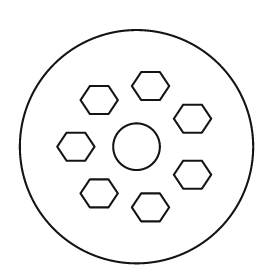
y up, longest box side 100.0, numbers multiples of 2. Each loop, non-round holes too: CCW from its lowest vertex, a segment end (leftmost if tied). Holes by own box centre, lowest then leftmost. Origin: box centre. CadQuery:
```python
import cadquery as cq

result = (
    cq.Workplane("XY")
    .moveTo(0.0, 0.0)
    .circle(50.0)
    .moveTo(2.0, -32.0)
    .lineTo(10.0, -32.0)
    .lineTo(14.0, -26.0)
    .lineTo(10.0, -20.0)
    .lineTo(2.0, -20.0)
    .lineTo(-2.0, -26.0)
    .close()
    .moveTo(-20.0, -26.0)
    .lineTo(-12.0, -26.0)
    .lineTo(-8.0, -20.0)
    .lineTo(-12.0, -14.0)
    .lineTo(-20.0, -14.0)
    .lineTo(-24.0, -20.0)
    .close()
    .moveTo(20.0, -18.0)
    .lineTo(28.0, -18.0)
    .lineTo(32.0, -12.0)
    .lineTo(28.0, -6.0)
    .lineTo(20.0, -6.0)
    .lineTo(16.0, -12.0)
    .close()
    .moveTo(-30.0, -6.0)
    .lineTo(-22.0, -6.0)
    .lineTo(-18.0, 0.0)
    .lineTo(-22.0, 6.0)
    .lineTo(-30.0, 6.0)
    .lineTo(-34.0, 0.0)
    .close()
    .moveTo(0.0, 0.0)
    .circle(10.0)
    .moveTo(20.0, 6.0)
    .lineTo(28.0, 6.0)
    .lineTo(32.0, 12.0)
    .lineTo(28.0, 18.0)
    .lineTo(20.0, 18.0)
    .lineTo(16.0, 12.0)
    .close()
    .moveTo(-20.0, 14.0)
    .lineTo(-12.0, 14.0)
    .lineTo(-8.0, 20.0)
    .lineTo(-12.0, 26.0)
    .lineTo(-20.0, 26.0)
    .lineTo(-24.0, 20.0)
    .close()
    .moveTo(2.0, 20.0)
    .lineTo(10.0, 20.0)
    .lineTo(14.0, 26.0)
    .lineTo(10.0, 32.0)
    .lineTo(2.0, 32.0)
    .lineTo(-2.0, 26.0)
    .close()
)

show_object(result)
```